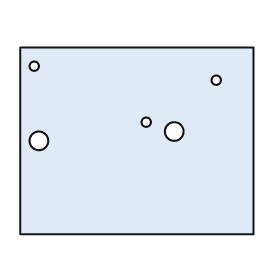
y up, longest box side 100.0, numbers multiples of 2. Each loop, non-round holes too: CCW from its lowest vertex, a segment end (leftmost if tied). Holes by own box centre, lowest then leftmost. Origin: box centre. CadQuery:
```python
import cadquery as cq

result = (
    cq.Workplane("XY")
    .moveTo(-50.0, -40.0)
    .lineTo(50.0, -40.0)
    .lineTo(50.0, 40.0)
    .lineTo(-50.0, 40.0)
    .close()
    .moveTo(-42.0, 0.0)
    .circle(4.0)
    .moveTo(16.0, 4.0)
    .circle(4.0)
    .moveTo(4.0, 8.0)
    .circle(2.0)
    .moveTo(34.0, 26.0)
    .circle(2.0)
    .moveTo(-44.0, 32.0)
    .circle(2.0)
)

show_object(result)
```